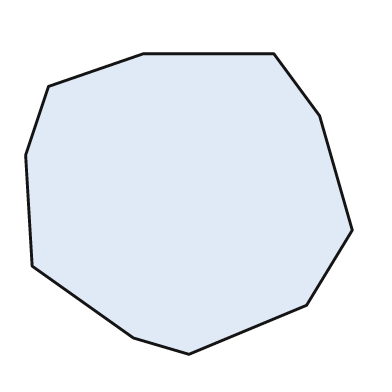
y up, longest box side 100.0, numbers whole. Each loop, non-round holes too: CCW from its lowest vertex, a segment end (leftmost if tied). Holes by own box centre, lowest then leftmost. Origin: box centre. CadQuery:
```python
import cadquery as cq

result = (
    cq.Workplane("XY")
    .moveTo(0.0, -46.0)
    .lineTo(36.0, -31.0)
    .lineTo(50.0, -8.0)
    .lineTo(40.0, 27.0)
    .lineTo(26.0, 46.0)
    .lineTo(-14.0, 46.0)
    .lineTo(-43.0, 36.0)
    .lineTo(-50.0, 15.0)
    .lineTo(-48.0, -19.0)
    .lineTo(-17.0, -41.0)
    .close()
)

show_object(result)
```